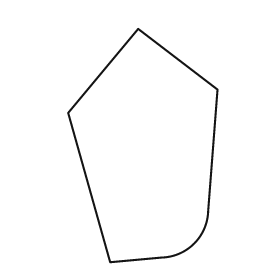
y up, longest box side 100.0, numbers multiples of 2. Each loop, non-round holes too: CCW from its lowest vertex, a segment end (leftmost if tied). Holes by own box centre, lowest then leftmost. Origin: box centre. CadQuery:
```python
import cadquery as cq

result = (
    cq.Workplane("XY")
    .moveTo(-14.0, -50.0)
    .lineTo(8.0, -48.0)
    .threePointArc((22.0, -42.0), (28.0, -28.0))
    .lineTo(32.0, 24.0)
    .lineTo(-2.0, 50.0)
    .lineTo(-32.0, 14.0)
    .close()
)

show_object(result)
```